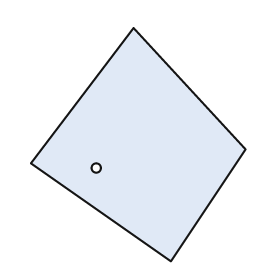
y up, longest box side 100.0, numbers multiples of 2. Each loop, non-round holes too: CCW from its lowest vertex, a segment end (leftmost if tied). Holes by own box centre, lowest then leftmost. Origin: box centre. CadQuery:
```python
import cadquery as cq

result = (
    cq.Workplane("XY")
    .moveTo(14.0, -50.0)
    .lineTo(46.0, -2.0)
    .lineTo(-2.0, 50.0)
    .lineTo(-46.0, -8.0)
    .close()
    .moveTo(-18.0, -10.0)
    .circle(2.0)
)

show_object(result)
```